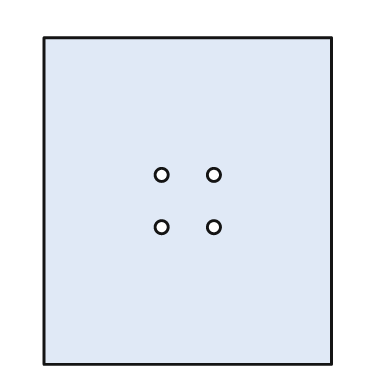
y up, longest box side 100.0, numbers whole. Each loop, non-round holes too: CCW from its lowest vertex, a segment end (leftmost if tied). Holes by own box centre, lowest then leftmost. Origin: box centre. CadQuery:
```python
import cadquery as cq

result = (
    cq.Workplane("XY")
    .moveTo(-44.0, -50.0)
    .lineTo(44.0, -50.0)
    .lineTo(44.0, 50.0)
    .lineTo(-44.0, 50.0)
    .close()
    .moveTo(-8.0, -8.0)
    .circle(2.0)
    .moveTo(8.0, -8.0)
    .circle(2.0)
    .moveTo(-8.0, 8.0)
    .circle(2.0)
    .moveTo(8.0, 8.0)
    .circle(2.0)
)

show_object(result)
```